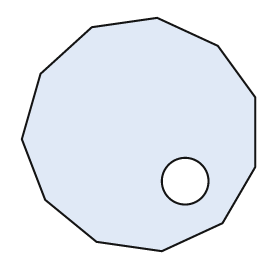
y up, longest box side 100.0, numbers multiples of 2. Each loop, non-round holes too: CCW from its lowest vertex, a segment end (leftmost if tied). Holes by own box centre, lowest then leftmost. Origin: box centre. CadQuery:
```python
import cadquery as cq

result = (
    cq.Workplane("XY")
    .moveTo(10.0, -50.0)
    .lineTo(36.0, -38.0)
    .lineTo(50.0, -14.0)
    .lineTo(50.0, 16.0)
    .lineTo(34.0, 38.0)
    .lineTo(8.0, 50.0)
    .lineTo(-20.0, 46.0)
    .lineTo(-42.0, 26.0)
    .lineTo(-50.0, -2.0)
    .lineTo(-40.0, -28.0)
    .lineTo(-18.0, -46.0)
    .close()
    .moveTo(20.0, -20.0)
    .circle(10.0)
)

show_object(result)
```